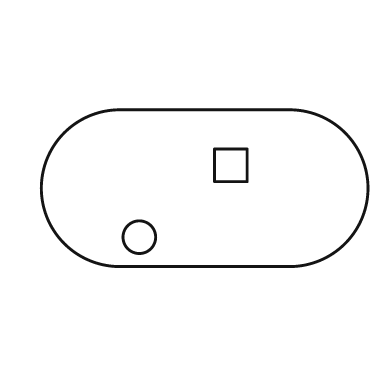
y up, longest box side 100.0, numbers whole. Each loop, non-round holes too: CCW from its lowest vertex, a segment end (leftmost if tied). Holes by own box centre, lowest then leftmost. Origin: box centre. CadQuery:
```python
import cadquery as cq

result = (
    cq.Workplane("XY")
    .moveTo(-26.0, -24.0)
    .lineTo(26.0, -24.0)
    .threePointArc((50.0, 0.0), (26.0, 24.0))
    .lineTo(-26.0, 24.0)
    .threePointArc((-50.0, 0.0), (-26.0, -24.0))
    .close()
    .moveTo(-20.0, -15.0)
    .circle(5.0)
    .moveTo(3.0, 2.0)
    .lineTo(13.0, 2.0)
    .lineTo(13.0, 12.0)
    .lineTo(3.0, 12.0)
    .close()
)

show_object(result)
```